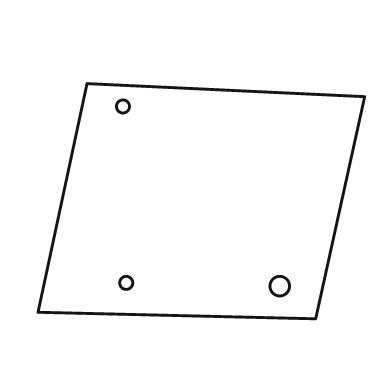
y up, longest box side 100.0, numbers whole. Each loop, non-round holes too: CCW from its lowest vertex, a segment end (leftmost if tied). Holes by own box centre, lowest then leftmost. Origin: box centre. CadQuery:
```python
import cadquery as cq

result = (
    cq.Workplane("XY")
    .moveTo(35.0, -36.0)
    .lineTo(50.0, 32.0)
    .lineTo(-35.0, 36.0)
    .lineTo(-50.0, -34.0)
    .close()
    .moveTo(24.0, -26.0)
    .circle(3.0)
    .moveTo(-23.0, -25.0)
    .circle(2.0)
    .moveTo(-24.0, 29.0)
    .circle(2.0)
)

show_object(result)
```